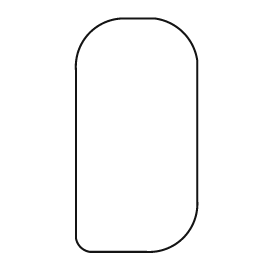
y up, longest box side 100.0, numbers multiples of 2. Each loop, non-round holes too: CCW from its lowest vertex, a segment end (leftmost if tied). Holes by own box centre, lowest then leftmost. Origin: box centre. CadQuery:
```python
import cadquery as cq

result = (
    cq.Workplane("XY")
    .moveTo(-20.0, -50.0)
    .lineTo(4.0, -50.0)
    .threePointArc((20.0, -44.0), (26.0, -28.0))
    .lineTo(26.0, 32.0)
    .threePointArc((20.0, 44.0), (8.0, 50.0))
    .lineTo(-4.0, 50.0)
    .threePointArc((-20.0, 44.0), (-26.0, 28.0))
    .lineTo(-26.0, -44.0)
    .threePointArc((-24.0, -48.0), (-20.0, -50.0))
    .close()
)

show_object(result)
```